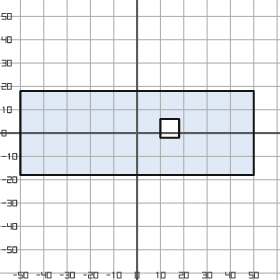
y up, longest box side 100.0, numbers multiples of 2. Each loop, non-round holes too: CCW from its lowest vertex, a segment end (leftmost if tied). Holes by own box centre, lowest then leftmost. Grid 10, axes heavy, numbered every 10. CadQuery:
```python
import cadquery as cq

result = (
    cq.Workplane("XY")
    .moveTo(-50.0, -18.0)
    .lineTo(50.0, -18.0)
    .lineTo(50.0, 18.0)
    .lineTo(-50.0, 18.0)
    .close()
    .moveTo(10.0, -2.0)
    .lineTo(18.0, -2.0)
    .lineTo(18.0, 6.0)
    .lineTo(10.0, 6.0)
    .close()
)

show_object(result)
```